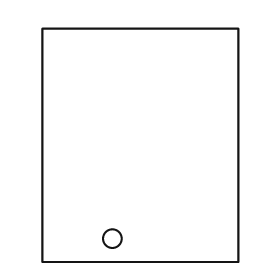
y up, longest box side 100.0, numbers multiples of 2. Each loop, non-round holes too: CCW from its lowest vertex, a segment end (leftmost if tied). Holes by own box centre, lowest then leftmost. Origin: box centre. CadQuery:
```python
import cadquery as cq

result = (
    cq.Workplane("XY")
    .moveTo(-42.0, -50.0)
    .lineTo(42.0, -50.0)
    .lineTo(42.0, 50.0)
    .lineTo(-42.0, 50.0)
    .close()
    .moveTo(-12.0, -40.0)
    .circle(4.0)
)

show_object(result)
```